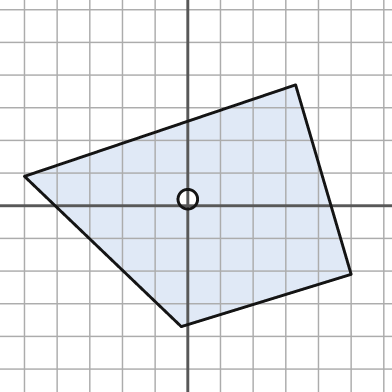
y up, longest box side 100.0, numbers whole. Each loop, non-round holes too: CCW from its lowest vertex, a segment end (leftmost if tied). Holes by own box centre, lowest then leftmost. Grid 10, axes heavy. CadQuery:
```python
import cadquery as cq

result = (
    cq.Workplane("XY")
    .moveTo(-2.0, -37.0)
    .lineTo(50.0, -21.0)
    .lineTo(33.0, 37.0)
    .lineTo(-50.0, 9.0)
    .close()
    .moveTo(0.0, 2.0)
    .circle(3.0)
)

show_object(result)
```